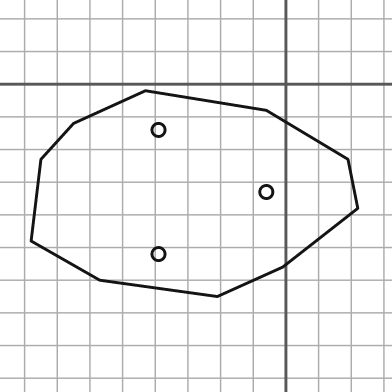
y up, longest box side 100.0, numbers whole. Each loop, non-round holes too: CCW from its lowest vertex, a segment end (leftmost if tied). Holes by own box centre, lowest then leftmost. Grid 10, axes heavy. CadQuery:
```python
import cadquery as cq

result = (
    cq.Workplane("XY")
    .moveTo(-21.0, -65.0)
    .lineTo(-1.0, -56.0)
    .lineTo(22.0, -38.0)
    .lineTo(19.0, -23.0)
    .lineTo(-6.0, -8.0)
    .lineTo(-43.0, -2.0)
    .lineTo(-65.0, -12.0)
    .lineTo(-75.0, -23.0)
    .lineTo(-78.0, -48.0)
    .lineTo(-57.0, -60.0)
    .close()
    .moveTo(-39.0, -52.0)
    .circle(2.0)
    .moveTo(-6.0, -33.0)
    .circle(2.0)
    .moveTo(-39.0, -14.0)
    .circle(2.0)
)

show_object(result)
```